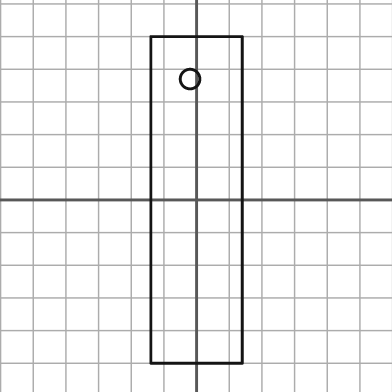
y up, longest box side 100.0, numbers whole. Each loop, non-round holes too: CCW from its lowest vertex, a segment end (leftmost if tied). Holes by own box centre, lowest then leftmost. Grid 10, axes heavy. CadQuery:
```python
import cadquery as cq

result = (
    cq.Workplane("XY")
    .moveTo(-14.0, -50.0)
    .lineTo(14.0, -50.0)
    .lineTo(14.0, 50.0)
    .lineTo(-14.0, 50.0)
    .close()
    .moveTo(-2.0, 37.0)
    .circle(3.0)
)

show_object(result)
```